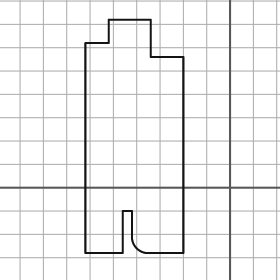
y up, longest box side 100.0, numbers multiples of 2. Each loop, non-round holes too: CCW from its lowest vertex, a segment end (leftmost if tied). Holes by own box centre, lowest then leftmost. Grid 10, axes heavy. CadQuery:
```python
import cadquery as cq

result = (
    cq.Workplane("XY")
    .moveTo(-62.0, -28.0)
    .lineTo(-46.0, -28.0)
    .lineTo(-46.0, -10.0)
    .lineTo(-42.0, -10.0)
    .lineTo(-42.0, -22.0)
    .threePointArc((-40.0, -26.0), (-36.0, -28.0))
    .lineTo(-20.0, -28.0)
    .lineTo(-20.0, 56.0)
    .lineTo(-34.0, 56.0)
    .lineTo(-34.0, 72.0)
    .lineTo(-52.0, 72.0)
    .lineTo(-52.0, 62.0)
    .lineTo(-62.0, 62.0)
    .close()
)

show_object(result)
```